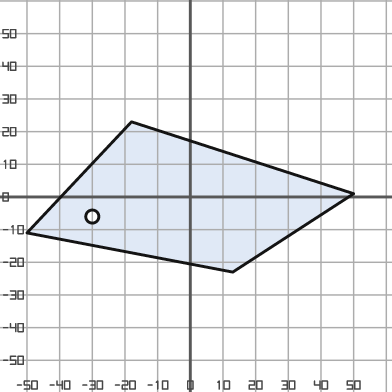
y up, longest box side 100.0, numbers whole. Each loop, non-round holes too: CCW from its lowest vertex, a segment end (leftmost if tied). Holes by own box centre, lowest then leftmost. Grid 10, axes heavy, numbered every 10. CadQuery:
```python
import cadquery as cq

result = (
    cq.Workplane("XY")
    .moveTo(13.0, -23.0)
    .lineTo(50.0, 1.0)
    .lineTo(-18.0, 23.0)
    .lineTo(-50.0, -11.0)
    .close()
    .moveTo(-30.0, -6.0)
    .circle(2.0)
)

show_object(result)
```